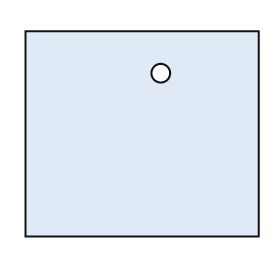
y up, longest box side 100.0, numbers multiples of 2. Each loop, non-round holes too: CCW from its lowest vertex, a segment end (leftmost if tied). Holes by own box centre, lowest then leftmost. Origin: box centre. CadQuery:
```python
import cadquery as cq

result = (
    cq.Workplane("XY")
    .moveTo(-50.0, -44.0)
    .lineTo(50.0, -44.0)
    .lineTo(50.0, 44.0)
    .lineTo(-50.0, 44.0)
    .close()
    .moveTo(8.0, 26.0)
    .circle(4.0)
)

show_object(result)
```